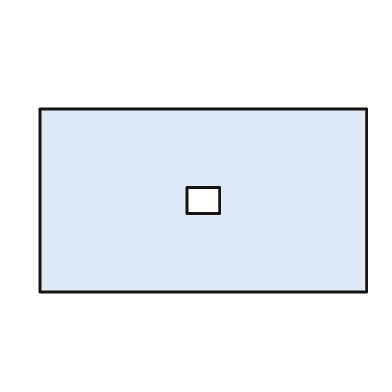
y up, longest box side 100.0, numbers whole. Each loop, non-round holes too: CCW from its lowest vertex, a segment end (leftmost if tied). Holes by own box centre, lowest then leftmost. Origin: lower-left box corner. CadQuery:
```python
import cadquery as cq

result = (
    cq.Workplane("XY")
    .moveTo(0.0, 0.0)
    .lineTo(100.0, 0.0)
    .lineTo(100.0, 56.0)
    .lineTo(0.0, 56.0)
    .close()
    .moveTo(45.0, 24.0)
    .lineTo(55.0, 24.0)
    .lineTo(55.0, 32.0)
    .lineTo(45.0, 32.0)
    .close()
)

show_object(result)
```